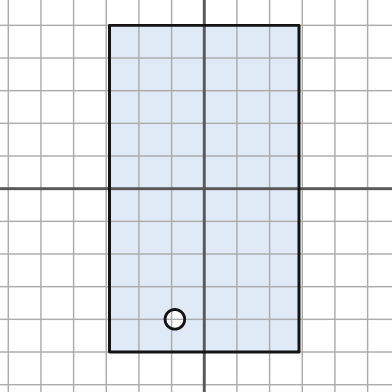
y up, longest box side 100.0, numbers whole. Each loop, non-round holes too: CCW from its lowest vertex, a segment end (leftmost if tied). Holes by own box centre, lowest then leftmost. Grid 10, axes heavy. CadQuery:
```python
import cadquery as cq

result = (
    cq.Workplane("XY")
    .moveTo(-29.0, -50.0)
    .lineTo(29.0, -50.0)
    .lineTo(29.0, 50.0)
    .lineTo(-29.0, 50.0)
    .close()
    .moveTo(-9.0, -40.0)
    .circle(3.0)
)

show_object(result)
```